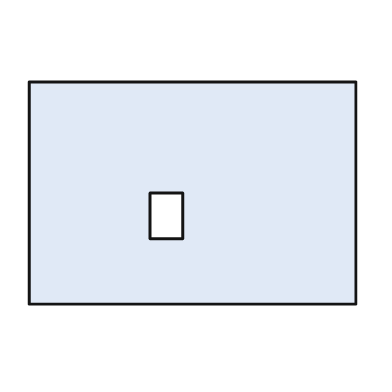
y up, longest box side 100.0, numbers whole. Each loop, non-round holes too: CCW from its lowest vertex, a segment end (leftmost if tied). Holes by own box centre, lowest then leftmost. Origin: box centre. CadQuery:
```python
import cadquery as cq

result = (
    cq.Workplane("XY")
    .moveTo(-50.0, -34.0)
    .lineTo(50.0, -34.0)
    .lineTo(50.0, 34.0)
    .lineTo(-50.0, 34.0)
    .close()
    .moveTo(-13.0, -14.0)
    .lineTo(-3.0, -14.0)
    .lineTo(-3.0, 0.0)
    .lineTo(-13.0, 0.0)
    .close()
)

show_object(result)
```